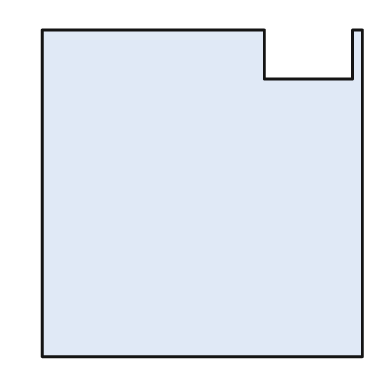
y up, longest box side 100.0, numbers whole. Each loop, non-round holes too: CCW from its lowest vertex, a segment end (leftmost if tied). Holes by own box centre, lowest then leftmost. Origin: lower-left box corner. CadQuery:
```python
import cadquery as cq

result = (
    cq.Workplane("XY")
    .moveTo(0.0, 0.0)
    .lineTo(98.0, 0.0)
    .lineTo(98.0, 100.0)
    .lineTo(95.0, 100.0)
    .lineTo(95.0, 85.0)
    .lineTo(68.0, 85.0)
    .lineTo(68.0, 100.0)
    .lineTo(0.0, 100.0)
    .close()
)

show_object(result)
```